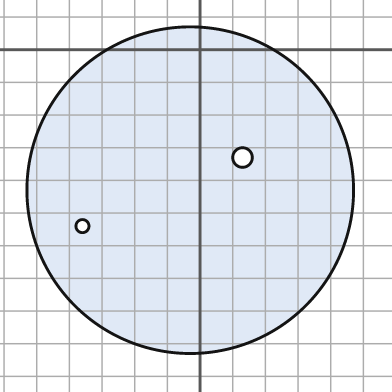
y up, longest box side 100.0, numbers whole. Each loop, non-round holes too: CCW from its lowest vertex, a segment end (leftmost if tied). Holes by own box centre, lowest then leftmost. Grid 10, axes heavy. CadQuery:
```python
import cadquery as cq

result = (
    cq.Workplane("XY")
    .moveTo(-3.0, -43.0)
    .circle(50.0)
    .moveTo(-36.0, -54.0)
    .circle(2.0)
    .moveTo(13.0, -33.0)
    .circle(3.0)
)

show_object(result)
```